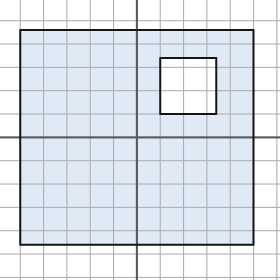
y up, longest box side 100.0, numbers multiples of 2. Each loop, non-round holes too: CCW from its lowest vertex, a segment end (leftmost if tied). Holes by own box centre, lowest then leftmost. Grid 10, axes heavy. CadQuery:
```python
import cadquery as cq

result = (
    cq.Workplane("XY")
    .moveTo(-50.0, -46.0)
    .lineTo(50.0, -46.0)
    .lineTo(50.0, 46.0)
    .lineTo(-50.0, 46.0)
    .close()
    .moveTo(10.0, 10.0)
    .lineTo(34.0, 10.0)
    .lineTo(34.0, 34.0)
    .lineTo(10.0, 34.0)
    .close()
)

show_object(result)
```